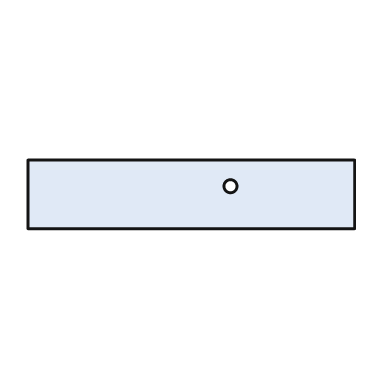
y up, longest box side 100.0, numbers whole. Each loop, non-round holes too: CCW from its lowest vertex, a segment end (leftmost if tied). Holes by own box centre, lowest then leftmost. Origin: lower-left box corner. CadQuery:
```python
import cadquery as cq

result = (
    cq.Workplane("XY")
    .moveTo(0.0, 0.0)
    .lineTo(100.0, 0.0)
    .lineTo(100.0, 21.0)
    .lineTo(0.0, 21.0)
    .close()
    .moveTo(62.0, 13.0)
    .circle(2.0)
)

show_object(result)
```